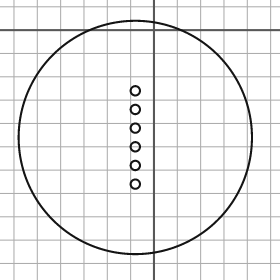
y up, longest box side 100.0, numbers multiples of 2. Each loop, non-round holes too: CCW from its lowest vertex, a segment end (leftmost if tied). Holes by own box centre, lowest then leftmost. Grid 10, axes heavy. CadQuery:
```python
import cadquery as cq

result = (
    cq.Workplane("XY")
    .moveTo(-8.0, -46.0)
    .circle(50.0)
    .moveTo(-8.0, -66.0)
    .circle(2.0)
    .moveTo(-8.0, -58.0)
    .circle(2.0)
    .moveTo(-8.0, -50.0)
    .circle(2.0)
    .moveTo(-8.0, -42.0)
    .circle(2.0)
    .moveTo(-8.0, -34.0)
    .circle(2.0)
    .moveTo(-8.0, -26.0)
    .circle(2.0)
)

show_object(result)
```